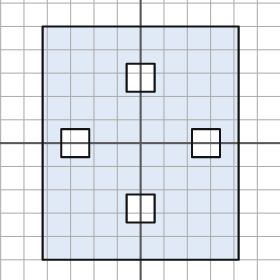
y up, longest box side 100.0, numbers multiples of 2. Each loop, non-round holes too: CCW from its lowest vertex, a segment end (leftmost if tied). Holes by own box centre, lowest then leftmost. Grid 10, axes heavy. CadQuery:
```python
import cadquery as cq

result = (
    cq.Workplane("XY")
    .moveTo(-42.0, -50.0)
    .lineTo(42.0, -50.0)
    .lineTo(42.0, 50.0)
    .lineTo(-42.0, 50.0)
    .close()
    .moveTo(-6.0, -34.0)
    .lineTo(6.0, -34.0)
    .lineTo(6.0, -22.0)
    .lineTo(-6.0, -22.0)
    .close()
    .moveTo(-34.0, -6.0)
    .lineTo(-22.0, -6.0)
    .lineTo(-22.0, 6.0)
    .lineTo(-34.0, 6.0)
    .close()
    .moveTo(22.0, -6.0)
    .lineTo(34.0, -6.0)
    .lineTo(34.0, 6.0)
    .lineTo(22.0, 6.0)
    .close()
    .moveTo(-6.0, 22.0)
    .lineTo(6.0, 22.0)
    .lineTo(6.0, 34.0)
    .lineTo(-6.0, 34.0)
    .close()
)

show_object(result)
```